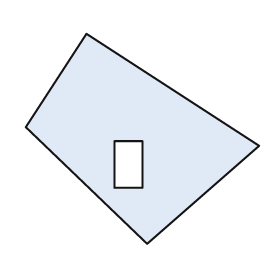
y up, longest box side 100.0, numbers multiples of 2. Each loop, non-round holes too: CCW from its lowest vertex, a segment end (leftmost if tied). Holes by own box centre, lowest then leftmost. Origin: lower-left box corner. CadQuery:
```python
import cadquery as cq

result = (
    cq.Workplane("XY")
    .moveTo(52.0, 0.0)
    .lineTo(100.0, 42.0)
    .lineTo(26.0, 90.0)
    .lineTo(0.0, 50.0)
    .close()
    .moveTo(38.0, 24.0)
    .lineTo(50.0, 24.0)
    .lineTo(50.0, 44.0)
    .lineTo(38.0, 44.0)
    .close()
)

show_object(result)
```